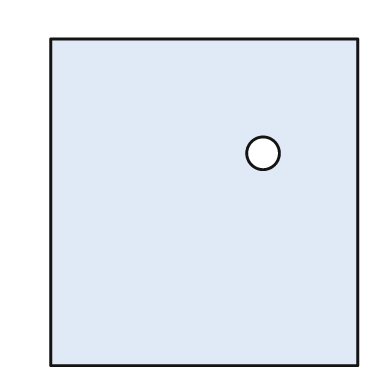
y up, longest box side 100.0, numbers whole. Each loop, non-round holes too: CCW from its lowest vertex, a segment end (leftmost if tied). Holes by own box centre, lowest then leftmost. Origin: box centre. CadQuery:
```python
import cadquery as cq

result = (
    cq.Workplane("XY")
    .moveTo(-47.0, -50.0)
    .lineTo(47.0, -50.0)
    .lineTo(47.0, 50.0)
    .lineTo(-47.0, 50.0)
    .close()
    .moveTo(18.0, 15.0)
    .circle(5.0)
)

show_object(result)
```